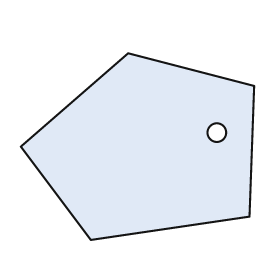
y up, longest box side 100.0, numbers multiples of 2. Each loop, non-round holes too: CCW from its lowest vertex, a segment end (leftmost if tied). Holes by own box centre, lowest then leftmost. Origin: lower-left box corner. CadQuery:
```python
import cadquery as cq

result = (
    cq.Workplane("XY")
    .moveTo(30.0, 0.0)
    .lineTo(98.0, 10.0)
    .lineTo(100.0, 66.0)
    .lineTo(46.0, 80.0)
    .lineTo(0.0, 40.0)
    .close()
    .moveTo(84.0, 46.0)
    .circle(4.0)
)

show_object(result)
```